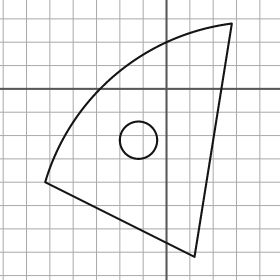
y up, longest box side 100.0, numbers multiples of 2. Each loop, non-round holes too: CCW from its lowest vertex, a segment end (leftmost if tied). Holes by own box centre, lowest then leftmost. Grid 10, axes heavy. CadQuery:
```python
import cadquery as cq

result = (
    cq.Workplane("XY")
    .moveTo(12.0, -72.0)
    .lineTo(28.0, 28.0)
    .threePointArc((-22.0, 6.0), (-52.0, -40.0))
    .close()
    .moveTo(-12.0, -22.0)
    .circle(8.0)
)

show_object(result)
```